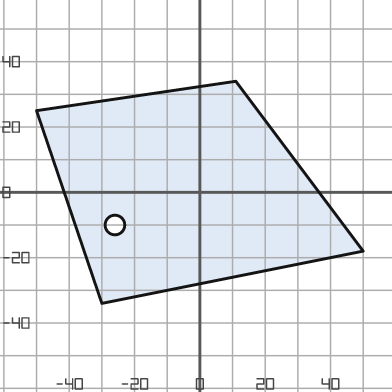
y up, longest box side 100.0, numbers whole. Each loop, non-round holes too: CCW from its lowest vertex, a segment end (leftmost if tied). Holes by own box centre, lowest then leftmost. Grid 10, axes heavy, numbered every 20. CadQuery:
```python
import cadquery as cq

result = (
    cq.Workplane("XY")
    .moveTo(-30.0, -34.0)
    .lineTo(50.0, -18.0)
    .lineTo(11.0, 34.0)
    .lineTo(-50.0, 25.0)
    .close()
    .moveTo(-26.0, -10.0)
    .circle(3.0)
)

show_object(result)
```